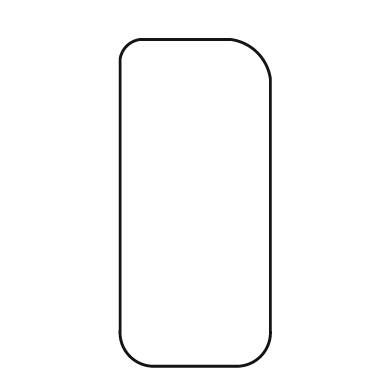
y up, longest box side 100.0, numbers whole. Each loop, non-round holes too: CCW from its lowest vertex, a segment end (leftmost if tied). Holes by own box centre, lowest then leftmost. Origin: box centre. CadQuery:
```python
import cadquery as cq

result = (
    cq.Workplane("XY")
    .moveTo(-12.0, -50.0)
    .lineTo(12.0, -50.0)
    .threePointArc((20.0, -47.0), (23.0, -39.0))
    .lineTo(23.0, 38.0)
    .threePointArc((19.0, 46.0), (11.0, 50.0))
    .lineTo(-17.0, 50.0)
    .threePointArc((-21.0, 48.0), (-23.0, 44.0))
    .lineTo(-23.0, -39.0)
    .threePointArc((-20.0, -47.0), (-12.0, -50.0))
    .close()
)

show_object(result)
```